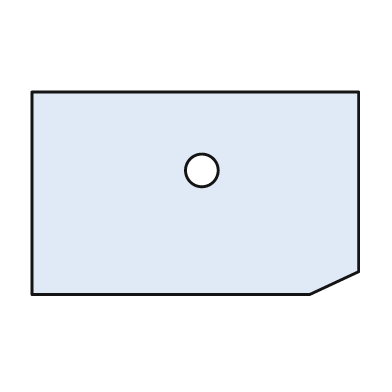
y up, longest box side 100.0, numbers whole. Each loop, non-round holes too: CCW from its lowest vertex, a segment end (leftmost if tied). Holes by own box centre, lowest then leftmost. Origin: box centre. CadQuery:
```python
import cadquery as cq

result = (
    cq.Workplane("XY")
    .moveTo(-50.0, -31.0)
    .lineTo(35.0, -31.0)
    .lineTo(50.0, -24.0)
    .lineTo(50.0, 31.0)
    .lineTo(-50.0, 31.0)
    .close()
    .moveTo(2.0, 7.0)
    .circle(5.0)
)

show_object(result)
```